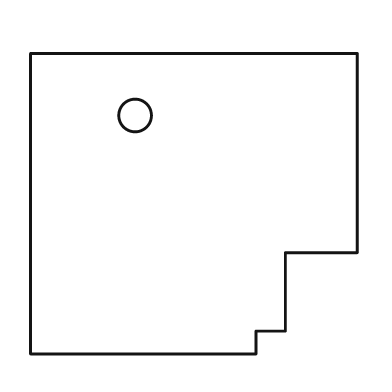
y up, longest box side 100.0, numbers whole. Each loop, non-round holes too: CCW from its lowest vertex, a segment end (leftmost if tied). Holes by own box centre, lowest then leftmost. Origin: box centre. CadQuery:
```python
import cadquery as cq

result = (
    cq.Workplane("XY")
    .moveTo(-50.0, -46.0)
    .lineTo(19.0, -46.0)
    .lineTo(19.0, -39.0)
    .lineTo(28.0, -39.0)
    .lineTo(28.0, -15.0)
    .lineTo(50.0, -15.0)
    .lineTo(50.0, 46.0)
    .lineTo(-50.0, 46.0)
    .close()
    .moveTo(-18.0, 27.0)
    .circle(5.0)
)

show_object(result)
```